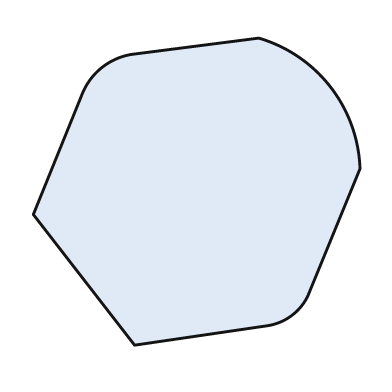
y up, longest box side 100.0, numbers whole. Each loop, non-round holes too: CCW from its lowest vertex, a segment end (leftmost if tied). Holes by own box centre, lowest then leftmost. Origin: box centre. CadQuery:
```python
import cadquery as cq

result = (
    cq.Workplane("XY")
    .moveTo(-19.0, -47.0)
    .lineTo(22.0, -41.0)
    .threePointArc((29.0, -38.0), (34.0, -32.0))
    .lineTo(50.0, 7.0)
    .threePointArc((41.0, 32.0), (19.0, 47.0))
    .lineTo(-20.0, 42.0)
    .threePointArc((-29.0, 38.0), (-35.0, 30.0))
    .lineTo(-50.0, -7.0)
    .close()
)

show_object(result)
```